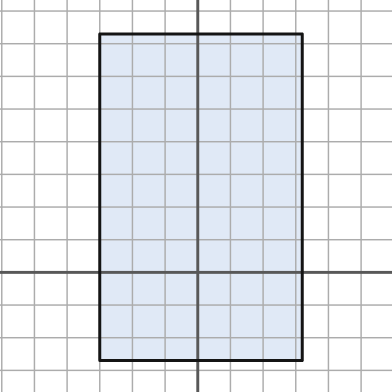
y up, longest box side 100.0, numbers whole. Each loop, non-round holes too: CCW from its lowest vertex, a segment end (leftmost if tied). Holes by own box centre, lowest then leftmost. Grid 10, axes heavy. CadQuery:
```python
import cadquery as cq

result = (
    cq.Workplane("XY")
    .moveTo(-30.0, -27.0)
    .lineTo(32.0, -27.0)
    .lineTo(32.0, 73.0)
    .lineTo(-30.0, 73.0)
    .close()
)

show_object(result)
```